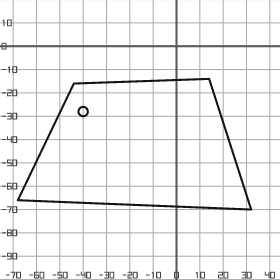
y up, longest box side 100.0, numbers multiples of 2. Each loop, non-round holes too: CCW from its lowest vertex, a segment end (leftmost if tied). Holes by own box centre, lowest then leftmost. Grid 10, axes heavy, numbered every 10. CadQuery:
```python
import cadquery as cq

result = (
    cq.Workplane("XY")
    .moveTo(32.0, -70.0)
    .lineTo(14.0, -14.0)
    .lineTo(-44.0, -16.0)
    .lineTo(-68.0, -66.0)
    .close()
    .moveTo(-40.0, -28.0)
    .circle(2.0)
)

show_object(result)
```